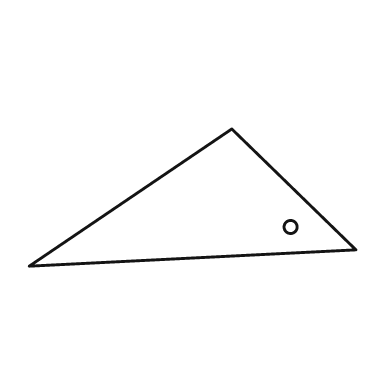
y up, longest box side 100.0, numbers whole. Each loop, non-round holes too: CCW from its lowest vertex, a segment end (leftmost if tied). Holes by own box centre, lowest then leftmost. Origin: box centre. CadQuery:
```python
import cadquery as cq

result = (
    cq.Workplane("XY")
    .moveTo(-50.0, -21.0)
    .lineTo(50.0, -16.0)
    .lineTo(12.0, 21.0)
    .close()
    .moveTo(30.0, -9.0)
    .circle(2.0)
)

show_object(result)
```